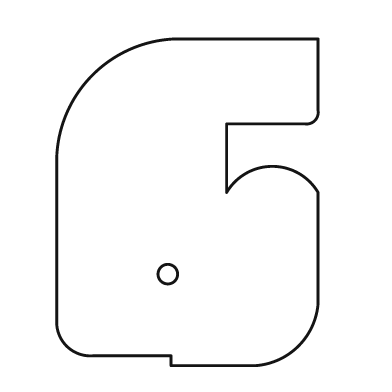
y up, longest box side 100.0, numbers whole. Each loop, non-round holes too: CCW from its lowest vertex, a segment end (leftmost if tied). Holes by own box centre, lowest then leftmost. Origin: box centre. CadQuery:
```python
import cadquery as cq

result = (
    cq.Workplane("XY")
    .moveTo(-5.0, -50.0)
    .lineTo(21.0, -50.0)
    .threePointArc((34.0, -44.0), (40.0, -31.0))
    .lineTo(40.0, 3.0)
    .threePointArc((26.0, 11.0), (12.0, 3.0))
    .lineTo(12.0, 24.0)
    .lineTo(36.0, 24.0)
    .threePointArc((39.0, 25.0), (40.0, 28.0))
    .lineTo(40.0, 50.0)
    .lineTo(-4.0, 50.0)
    .threePointArc((-29.0, 39.0), (-40.0, 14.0))
    .lineTo(-40.0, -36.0)
    .threePointArc((-37.0, -44.0), (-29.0, -47.0))
    .lineTo(-5.0, -47.0)
    .close()
    .moveTo(-6.0, -22.0)
    .circle(3.0)
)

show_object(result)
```